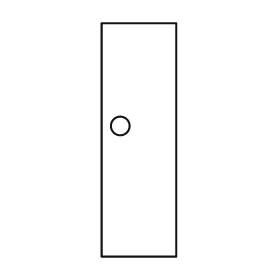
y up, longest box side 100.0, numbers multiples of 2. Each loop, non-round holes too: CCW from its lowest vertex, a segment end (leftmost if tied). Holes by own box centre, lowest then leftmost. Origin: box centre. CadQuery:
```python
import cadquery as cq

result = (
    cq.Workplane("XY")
    .moveTo(-16.0, -50.0)
    .lineTo(16.0, -50.0)
    .lineTo(16.0, 50.0)
    .lineTo(-16.0, 50.0)
    .close()
    .moveTo(-8.0, 6.0)
    .circle(4.0)
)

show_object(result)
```